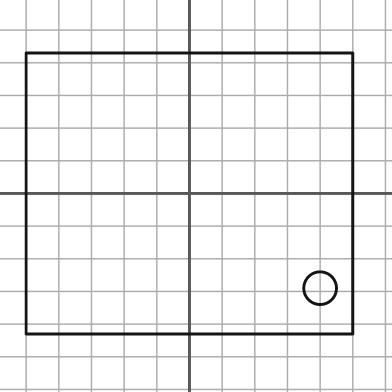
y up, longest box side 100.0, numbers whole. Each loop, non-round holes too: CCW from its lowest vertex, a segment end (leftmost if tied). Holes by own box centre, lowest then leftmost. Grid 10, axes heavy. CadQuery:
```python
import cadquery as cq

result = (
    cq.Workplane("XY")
    .moveTo(-50.0, -43.0)
    .lineTo(50.0, -43.0)
    .lineTo(50.0, 43.0)
    .lineTo(-50.0, 43.0)
    .close()
    .moveTo(40.0, -29.0)
    .circle(5.0)
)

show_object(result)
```